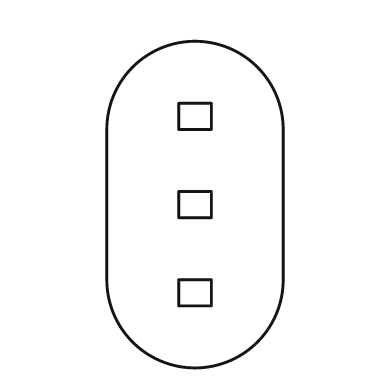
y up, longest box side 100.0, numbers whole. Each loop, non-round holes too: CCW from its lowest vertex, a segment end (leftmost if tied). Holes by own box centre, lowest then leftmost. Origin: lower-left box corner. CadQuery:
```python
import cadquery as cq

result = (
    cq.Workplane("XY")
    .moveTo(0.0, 27.0)
    .threePointArc((27.0, 0.0), (54.0, 27.0))
    .lineTo(54.0, 73.0)
    .threePointArc((27.0, 100.0), (0.0, 73.0))
    .close()
    .moveTo(22.0, 19.0)
    .lineTo(32.0, 19.0)
    .lineTo(32.0, 27.0)
    .lineTo(22.0, 27.0)
    .close()
    .moveTo(22.0, 46.0)
    .lineTo(32.0, 46.0)
    .lineTo(32.0, 54.0)
    .lineTo(22.0, 54.0)
    .close()
    .moveTo(22.0, 73.0)
    .lineTo(32.0, 73.0)
    .lineTo(32.0, 81.0)
    .lineTo(22.0, 81.0)
    .close()
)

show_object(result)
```